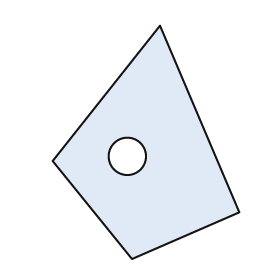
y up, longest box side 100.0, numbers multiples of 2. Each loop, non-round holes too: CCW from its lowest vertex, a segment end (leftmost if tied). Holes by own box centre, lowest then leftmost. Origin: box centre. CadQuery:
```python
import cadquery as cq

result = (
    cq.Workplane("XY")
    .moveTo(-6.0, -50.0)
    .lineTo(40.0, -30.0)
    .lineTo(6.0, 50.0)
    .lineTo(-40.0, -8.0)
    .close()
    .moveTo(-8.0, -6.0)
    .circle(8.0)
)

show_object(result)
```